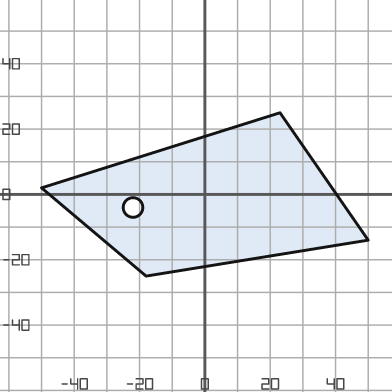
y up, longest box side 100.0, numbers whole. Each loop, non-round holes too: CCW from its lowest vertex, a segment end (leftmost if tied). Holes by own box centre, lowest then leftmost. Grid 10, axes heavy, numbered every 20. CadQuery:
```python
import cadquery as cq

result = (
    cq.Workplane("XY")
    .moveTo(-18.0, -25.0)
    .lineTo(50.0, -14.0)
    .lineTo(23.0, 25.0)
    .lineTo(-50.0, 2.0)
    .close()
    .moveTo(-22.0, -4.0)
    .circle(3.0)
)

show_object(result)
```